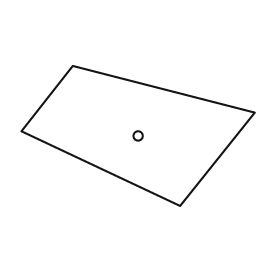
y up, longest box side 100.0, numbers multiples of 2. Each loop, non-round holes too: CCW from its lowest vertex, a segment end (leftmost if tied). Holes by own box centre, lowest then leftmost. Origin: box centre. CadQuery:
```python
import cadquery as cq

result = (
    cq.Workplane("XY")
    .moveTo(18.0, -30.0)
    .lineTo(50.0, 10.0)
    .lineTo(-28.0, 30.0)
    .lineTo(-50.0, 2.0)
    .close()
    .moveTo(0.0, 0.0)
    .circle(2.0)
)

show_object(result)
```